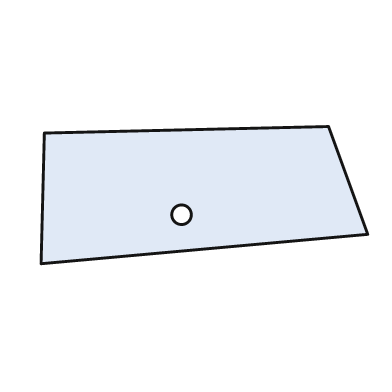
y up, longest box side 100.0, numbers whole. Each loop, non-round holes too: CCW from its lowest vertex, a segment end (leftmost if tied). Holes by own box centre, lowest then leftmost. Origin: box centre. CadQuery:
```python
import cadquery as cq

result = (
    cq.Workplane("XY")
    .moveTo(-50.0, -21.0)
    .lineTo(50.0, -12.0)
    .lineTo(38.0, 21.0)
    .lineTo(-49.0, 19.0)
    .close()
    .moveTo(-7.0, -6.0)
    .circle(3.0)
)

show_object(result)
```